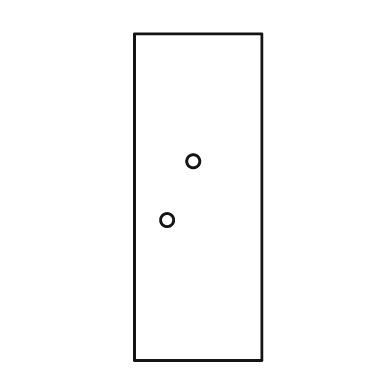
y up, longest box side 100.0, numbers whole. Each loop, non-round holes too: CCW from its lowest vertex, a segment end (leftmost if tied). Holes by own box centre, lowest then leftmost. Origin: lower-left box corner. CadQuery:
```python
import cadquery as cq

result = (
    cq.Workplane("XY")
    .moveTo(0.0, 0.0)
    .lineTo(39.0, 0.0)
    .lineTo(39.0, 100.0)
    .lineTo(0.0, 100.0)
    .close()
    .moveTo(10.0, 43.0)
    .circle(2.0)
    .moveTo(18.0, 61.0)
    .circle(2.0)
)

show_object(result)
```